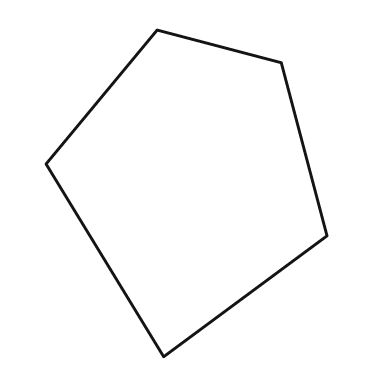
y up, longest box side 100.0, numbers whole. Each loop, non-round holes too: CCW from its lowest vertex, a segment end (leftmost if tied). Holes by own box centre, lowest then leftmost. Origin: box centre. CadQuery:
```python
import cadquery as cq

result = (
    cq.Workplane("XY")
    .moveTo(-7.0, -50.0)
    .lineTo(43.0, -13.0)
    .lineTo(29.0, 40.0)
    .lineTo(-9.0, 50.0)
    .lineTo(-43.0, 9.0)
    .close()
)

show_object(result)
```